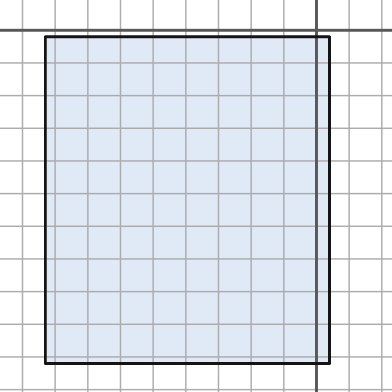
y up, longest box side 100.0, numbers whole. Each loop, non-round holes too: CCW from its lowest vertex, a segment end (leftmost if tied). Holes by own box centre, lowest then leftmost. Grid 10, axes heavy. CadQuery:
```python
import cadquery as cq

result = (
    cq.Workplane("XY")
    .moveTo(-83.0, -102.0)
    .lineTo(4.0, -102.0)
    .lineTo(4.0, -2.0)
    .lineTo(-83.0, -2.0)
    .close()
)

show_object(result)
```